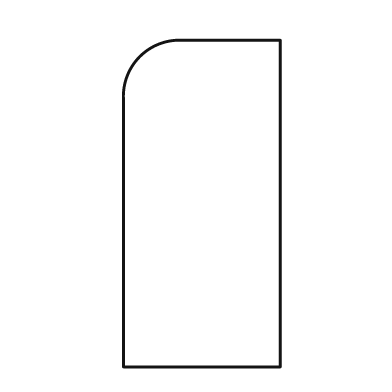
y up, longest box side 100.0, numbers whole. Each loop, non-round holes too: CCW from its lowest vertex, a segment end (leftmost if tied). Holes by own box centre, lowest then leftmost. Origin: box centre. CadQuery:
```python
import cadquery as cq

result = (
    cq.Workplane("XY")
    .moveTo(-24.0, -50.0)
    .lineTo(24.0, -50.0)
    .lineTo(24.0, 50.0)
    .lineTo(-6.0, 50.0)
    .threePointArc((-19.0, 45.0), (-24.0, 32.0))
    .close()
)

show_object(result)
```